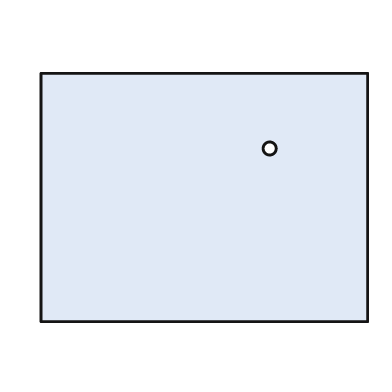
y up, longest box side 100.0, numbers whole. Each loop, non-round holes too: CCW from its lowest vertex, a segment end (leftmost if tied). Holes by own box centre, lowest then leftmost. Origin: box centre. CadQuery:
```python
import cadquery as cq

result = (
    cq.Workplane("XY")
    .moveTo(-50.0, -38.0)
    .lineTo(50.0, -38.0)
    .lineTo(50.0, 38.0)
    .lineTo(-50.0, 38.0)
    .close()
    .moveTo(20.0, 15.0)
    .circle(2.0)
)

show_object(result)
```